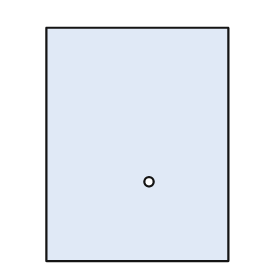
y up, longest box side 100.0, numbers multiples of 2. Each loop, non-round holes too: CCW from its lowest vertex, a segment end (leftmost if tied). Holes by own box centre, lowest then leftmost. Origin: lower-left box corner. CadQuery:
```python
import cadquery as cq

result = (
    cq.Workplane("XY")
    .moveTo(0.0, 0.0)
    .lineTo(78.0, 0.0)
    .lineTo(78.0, 100.0)
    .lineTo(0.0, 100.0)
    .close()
    .moveTo(44.0, 34.0)
    .circle(2.0)
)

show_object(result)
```